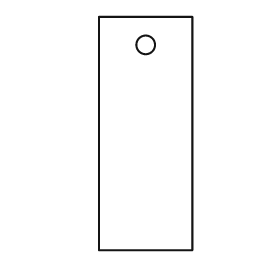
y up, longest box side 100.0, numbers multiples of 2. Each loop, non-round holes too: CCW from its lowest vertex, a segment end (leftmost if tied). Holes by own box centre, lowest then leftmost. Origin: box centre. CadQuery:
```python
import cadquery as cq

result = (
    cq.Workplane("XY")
    .moveTo(-20.0, -50.0)
    .lineTo(20.0, -50.0)
    .lineTo(20.0, 50.0)
    .lineTo(-20.0, 50.0)
    .close()
    .moveTo(0.0, 38.0)
    .circle(4.0)
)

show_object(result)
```